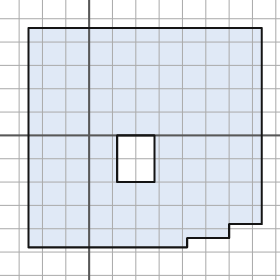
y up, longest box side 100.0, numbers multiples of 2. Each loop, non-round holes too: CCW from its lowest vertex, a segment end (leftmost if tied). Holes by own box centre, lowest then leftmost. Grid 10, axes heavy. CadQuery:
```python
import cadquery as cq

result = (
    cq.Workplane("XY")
    .moveTo(-26.0, -48.0)
    .lineTo(42.0, -48.0)
    .lineTo(42.0, -44.0)
    .lineTo(60.0, -44.0)
    .lineTo(60.0, -38.0)
    .lineTo(74.0, -38.0)
    .lineTo(74.0, 46.0)
    .lineTo(-26.0, 46.0)
    .close()
    .moveTo(12.0, -20.0)
    .lineTo(28.0, -20.0)
    .lineTo(28.0, 0.0)
    .lineTo(12.0, 0.0)
    .close()
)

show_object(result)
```